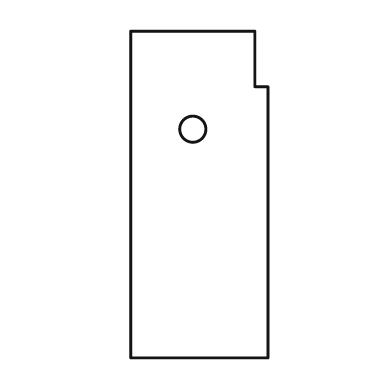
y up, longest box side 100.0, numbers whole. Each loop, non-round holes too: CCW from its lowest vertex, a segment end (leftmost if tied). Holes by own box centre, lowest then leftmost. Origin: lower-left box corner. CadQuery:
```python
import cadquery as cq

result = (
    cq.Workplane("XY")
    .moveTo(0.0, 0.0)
    .lineTo(42.0, 0.0)
    .lineTo(42.0, 83.0)
    .lineTo(38.0, 83.0)
    .lineTo(38.0, 100.0)
    .lineTo(0.0, 100.0)
    .close()
    .moveTo(19.0, 70.0)
    .circle(4.0)
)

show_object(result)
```